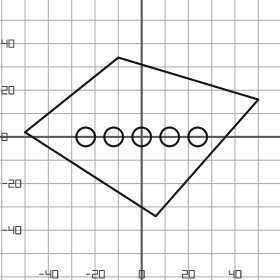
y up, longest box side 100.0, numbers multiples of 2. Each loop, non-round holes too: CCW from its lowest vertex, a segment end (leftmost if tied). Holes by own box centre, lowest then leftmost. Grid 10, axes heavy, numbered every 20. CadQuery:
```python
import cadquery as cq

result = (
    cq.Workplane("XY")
    .moveTo(6.0, -34.0)
    .lineTo(50.0, 16.0)
    .lineTo(-10.0, 34.0)
    .lineTo(-50.0, 2.0)
    .close()
    .moveTo(-24.0, 0.0)
    .circle(4.0)
    .moveTo(-12.0, 0.0)
    .circle(4.0)
    .moveTo(0.0, 0.0)
    .circle(4.0)
    .moveTo(12.0, 0.0)
    .circle(4.0)
    .moveTo(24.0, 0.0)
    .circle(4.0)
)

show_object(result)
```